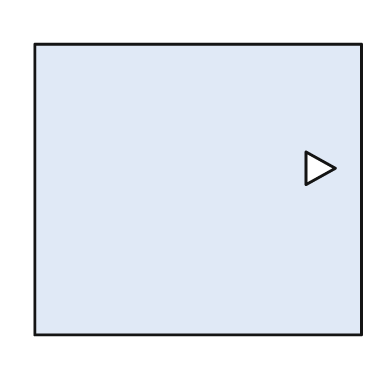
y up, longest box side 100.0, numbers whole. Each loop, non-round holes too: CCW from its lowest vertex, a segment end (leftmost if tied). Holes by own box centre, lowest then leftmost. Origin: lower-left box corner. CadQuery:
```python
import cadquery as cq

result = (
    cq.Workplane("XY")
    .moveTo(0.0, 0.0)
    .lineTo(100.0, 0.0)
    .lineTo(100.0, 89.0)
    .lineTo(0.0, 89.0)
    .close()
    .moveTo(83.0, 46.0)
    .lineTo(92.0, 51.0)
    .lineTo(83.0, 56.0)
    .close()
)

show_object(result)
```